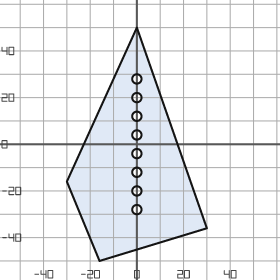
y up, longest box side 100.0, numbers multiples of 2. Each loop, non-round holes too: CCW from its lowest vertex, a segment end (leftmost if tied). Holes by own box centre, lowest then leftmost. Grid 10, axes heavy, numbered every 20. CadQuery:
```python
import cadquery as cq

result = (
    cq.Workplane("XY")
    .moveTo(-16.0, -50.0)
    .lineTo(30.0, -36.0)
    .lineTo(0.0, 50.0)
    .lineTo(-30.0, -16.0)
    .close()
    .moveTo(0.0, -28.0)
    .circle(2.0)
    .moveTo(0.0, -20.0)
    .circle(2.0)
    .moveTo(0.0, -12.0)
    .circle(2.0)
    .moveTo(0.0, -4.0)
    .circle(2.0)
    .moveTo(0.0, 4.0)
    .circle(2.0)
    .moveTo(0.0, 12.0)
    .circle(2.0)
    .moveTo(0.0, 20.0)
    .circle(2.0)
    .moveTo(0.0, 28.0)
    .circle(2.0)
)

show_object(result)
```